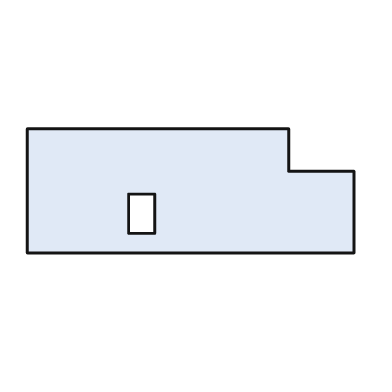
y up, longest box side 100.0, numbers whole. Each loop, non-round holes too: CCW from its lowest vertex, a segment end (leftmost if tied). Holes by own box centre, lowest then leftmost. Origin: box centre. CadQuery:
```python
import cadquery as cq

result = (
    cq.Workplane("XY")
    .moveTo(-50.0, -19.0)
    .lineTo(50.0, -19.0)
    .lineTo(50.0, 6.0)
    .lineTo(30.0, 6.0)
    .lineTo(30.0, 19.0)
    .lineTo(-50.0, 19.0)
    .close()
    .moveTo(-19.0, -13.0)
    .lineTo(-11.0, -13.0)
    .lineTo(-11.0, -1.0)
    .lineTo(-19.0, -1.0)
    .close()
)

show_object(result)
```